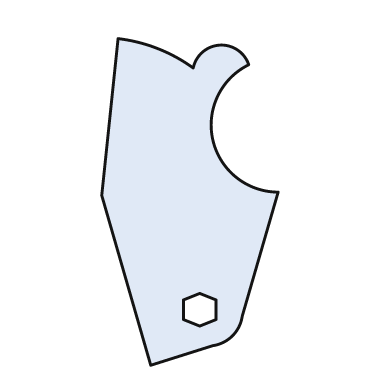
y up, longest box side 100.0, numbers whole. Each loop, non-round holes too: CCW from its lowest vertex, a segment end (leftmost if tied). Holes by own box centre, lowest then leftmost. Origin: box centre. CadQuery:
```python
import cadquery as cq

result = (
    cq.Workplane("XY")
    .moveTo(-12.0, -50.0)
    .lineTo(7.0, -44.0)
    .threePointArc((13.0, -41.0), (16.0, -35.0))
    .lineTo(27.0, 3.0)
    .threePointArc((7.0, 19.0), (18.0, 42.0))
    .threePointArc((9.0, 48.0), (1.0, 41.0))
    .threePointArc((-10.0, 47.0), (-22.0, 50.0))
    .lineTo(-27.0, 2.0)
    .close()
    .moveTo(3.0, -38.0)
    .lineTo(8.0, -36.0)
    .lineTo(8.0, -30.0)
    .lineTo(3.0, -28.0)
    .lineTo(-2.0, -30.0)
    .lineTo(-2.0, -36.0)
    .close()
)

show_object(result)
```